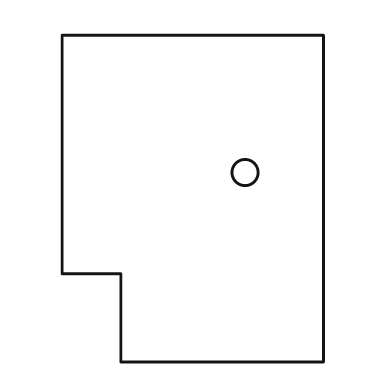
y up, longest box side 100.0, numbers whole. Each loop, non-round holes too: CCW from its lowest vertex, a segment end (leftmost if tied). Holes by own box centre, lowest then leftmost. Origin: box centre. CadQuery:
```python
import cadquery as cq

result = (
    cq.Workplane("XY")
    .moveTo(-22.0, -50.0)
    .lineTo(40.0, -50.0)
    .lineTo(40.0, 50.0)
    .lineTo(-40.0, 50.0)
    .lineTo(-40.0, -23.0)
    .lineTo(-22.0, -23.0)
    .close()
    .moveTo(16.0, 8.0)
    .circle(4.0)
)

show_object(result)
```